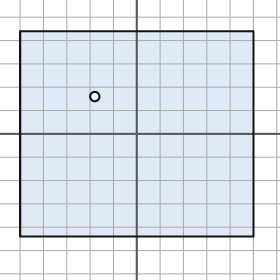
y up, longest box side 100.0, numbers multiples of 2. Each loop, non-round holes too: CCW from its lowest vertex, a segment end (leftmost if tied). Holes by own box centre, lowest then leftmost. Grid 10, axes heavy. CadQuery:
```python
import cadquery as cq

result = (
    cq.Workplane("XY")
    .moveTo(-50.0, -44.0)
    .lineTo(50.0, -44.0)
    .lineTo(50.0, 44.0)
    .lineTo(-50.0, 44.0)
    .close()
    .moveTo(-18.0, 16.0)
    .circle(2.0)
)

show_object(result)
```